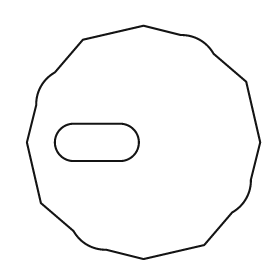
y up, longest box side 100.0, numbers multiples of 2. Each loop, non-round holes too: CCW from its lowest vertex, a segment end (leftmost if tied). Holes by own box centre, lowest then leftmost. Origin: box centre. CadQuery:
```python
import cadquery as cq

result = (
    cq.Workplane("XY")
    .moveTo(0.0, -50.0)
    .lineTo(26.0, -44.0)
    .lineTo(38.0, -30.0)
    .threePointArc((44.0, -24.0), (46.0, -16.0))
    .lineTo(50.0, 0.0)
    .lineTo(44.0, 26.0)
    .lineTo(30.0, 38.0)
    .threePointArc((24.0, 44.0), (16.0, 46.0))
    .lineTo(0.0, 50.0)
    .lineTo(-26.0, 44.0)
    .lineTo(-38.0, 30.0)
    .threePointArc((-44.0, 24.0), (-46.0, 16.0))
    .lineTo(-50.0, 0.0)
    .lineTo(-44.0, -26.0)
    .lineTo(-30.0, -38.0)
    .threePointArc((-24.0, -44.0), (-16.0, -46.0))
    .close()
    .moveTo(-30.0, -8.0)
    .lineTo(-10.0, -8.0)
    .threePointArc((-2.0, 0.0), (-10.0, 8.0))
    .lineTo(-30.0, 8.0)
    .threePointArc((-38.0, 0.0), (-30.0, -8.0))
    .close()
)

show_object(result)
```